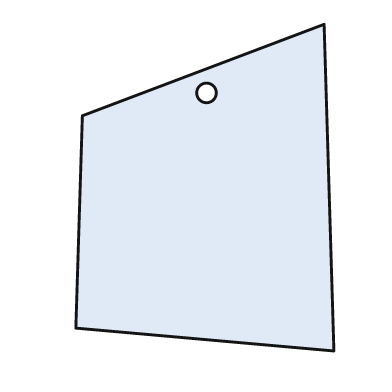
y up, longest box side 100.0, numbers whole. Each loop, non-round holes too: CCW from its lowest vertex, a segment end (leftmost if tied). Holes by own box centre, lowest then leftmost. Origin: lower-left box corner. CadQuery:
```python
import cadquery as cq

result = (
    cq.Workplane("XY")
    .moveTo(79.0, 0.0)
    .lineTo(76.0, 100.0)
    .lineTo(2.0, 72.0)
    .lineTo(0.0, 7.0)
    .close()
    .moveTo(40.0, 79.0)
    .circle(3.0)
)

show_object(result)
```